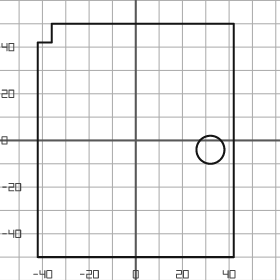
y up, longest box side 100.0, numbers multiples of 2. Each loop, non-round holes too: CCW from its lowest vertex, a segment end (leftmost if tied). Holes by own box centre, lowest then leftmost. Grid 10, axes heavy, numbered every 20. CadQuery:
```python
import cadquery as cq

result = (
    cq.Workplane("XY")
    .moveTo(-42.0, -50.0)
    .lineTo(42.0, -50.0)
    .lineTo(42.0, 50.0)
    .lineTo(-36.0, 50.0)
    .lineTo(-36.0, 42.0)
    .lineTo(-42.0, 42.0)
    .close()
    .moveTo(32.0, -4.0)
    .circle(6.0)
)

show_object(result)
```